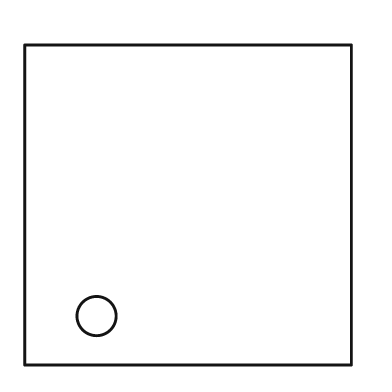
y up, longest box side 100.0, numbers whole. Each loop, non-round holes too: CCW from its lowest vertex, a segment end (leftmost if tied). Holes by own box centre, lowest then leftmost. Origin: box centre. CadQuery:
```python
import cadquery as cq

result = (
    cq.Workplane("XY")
    .moveTo(-50.0, -49.0)
    .lineTo(50.0, -49.0)
    .lineTo(50.0, 49.0)
    .lineTo(-50.0, 49.0)
    .close()
    .moveTo(-28.0, -34.0)
    .circle(6.0)
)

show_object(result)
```